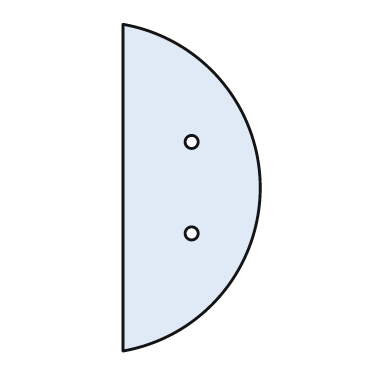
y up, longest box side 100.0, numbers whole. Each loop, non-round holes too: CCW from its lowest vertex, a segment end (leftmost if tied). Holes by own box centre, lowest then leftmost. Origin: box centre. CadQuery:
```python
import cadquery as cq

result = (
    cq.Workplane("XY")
    .moveTo(-21.0, -50.0)
    .threePointArc((21.0, 0.0), (-21.0, 50.0))
    .close()
    .moveTo(0.0, -14.0)
    .circle(2.0)
    .moveTo(0.0, 14.0)
    .circle(2.0)
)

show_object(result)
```